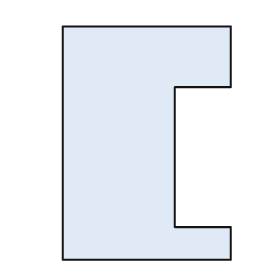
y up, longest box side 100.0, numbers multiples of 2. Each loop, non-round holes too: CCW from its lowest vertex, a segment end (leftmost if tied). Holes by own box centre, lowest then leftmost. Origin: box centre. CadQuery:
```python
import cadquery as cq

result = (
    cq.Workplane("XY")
    .moveTo(-36.0, -50.0)
    .lineTo(36.0, -50.0)
    .lineTo(36.0, -36.0)
    .lineTo(12.0, -36.0)
    .lineTo(12.0, 24.0)
    .lineTo(36.0, 24.0)
    .lineTo(36.0, 50.0)
    .lineTo(-36.0, 50.0)
    .close()
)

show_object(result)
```